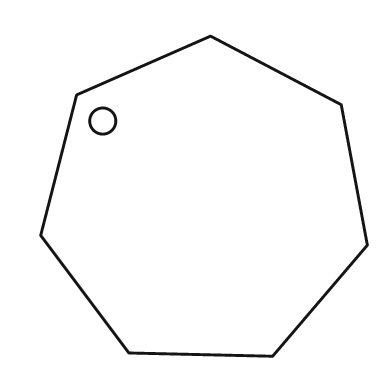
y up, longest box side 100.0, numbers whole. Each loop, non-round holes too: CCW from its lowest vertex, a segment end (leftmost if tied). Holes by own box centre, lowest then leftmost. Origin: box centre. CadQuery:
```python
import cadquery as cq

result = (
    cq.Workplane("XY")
    .moveTo(21.0, -49.0)
    .lineTo(50.0, -15.0)
    .lineTo(42.0, 28.0)
    .lineTo(2.0, 49.0)
    .lineTo(-39.0, 31.0)
    .lineTo(-50.0, -12.0)
    .lineTo(-23.0, -48.0)
    .close()
    .moveTo(-31.0, 23.0)
    .circle(4.0)
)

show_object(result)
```